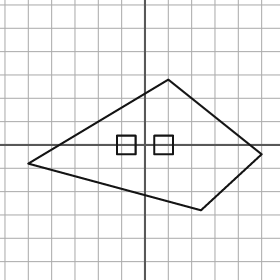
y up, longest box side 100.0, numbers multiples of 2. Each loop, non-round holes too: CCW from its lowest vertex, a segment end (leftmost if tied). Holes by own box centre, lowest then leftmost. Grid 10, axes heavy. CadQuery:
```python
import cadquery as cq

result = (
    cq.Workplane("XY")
    .moveTo(24.0, -28.0)
    .lineTo(50.0, -4.0)
    .lineTo(10.0, 28.0)
    .lineTo(-50.0, -8.0)
    .close()
    .moveTo(-12.0, -4.0)
    .lineTo(-4.0, -4.0)
    .lineTo(-4.0, 4.0)
    .lineTo(-12.0, 4.0)
    .close()
    .moveTo(4.0, -4.0)
    .lineTo(12.0, -4.0)
    .lineTo(12.0, 4.0)
    .lineTo(4.0, 4.0)
    .close()
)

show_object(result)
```